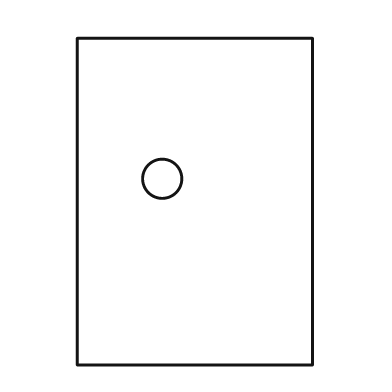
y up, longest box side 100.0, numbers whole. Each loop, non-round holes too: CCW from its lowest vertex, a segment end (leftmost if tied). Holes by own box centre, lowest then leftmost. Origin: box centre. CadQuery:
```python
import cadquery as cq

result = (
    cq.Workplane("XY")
    .moveTo(-36.0, -50.0)
    .lineTo(36.0, -50.0)
    .lineTo(36.0, 50.0)
    .lineTo(-36.0, 50.0)
    .close()
    .moveTo(-10.0, 7.0)
    .circle(6.0)
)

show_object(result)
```